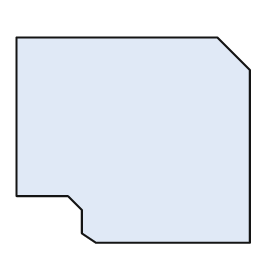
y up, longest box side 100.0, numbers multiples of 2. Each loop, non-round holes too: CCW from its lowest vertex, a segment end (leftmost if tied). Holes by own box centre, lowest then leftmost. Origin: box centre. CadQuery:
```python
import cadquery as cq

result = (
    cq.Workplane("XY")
    .moveTo(-16.0, -44.0)
    .lineTo(50.0, -44.0)
    .lineTo(50.0, 30.0)
    .lineTo(36.0, 44.0)
    .lineTo(-50.0, 44.0)
    .lineTo(-50.0, -24.0)
    .lineTo(-28.0, -24.0)
    .lineTo(-22.0, -30.0)
    .lineTo(-22.0, -40.0)
    .close()
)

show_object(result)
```